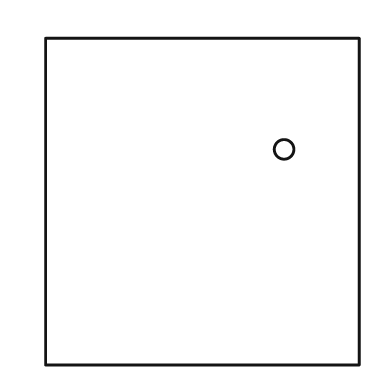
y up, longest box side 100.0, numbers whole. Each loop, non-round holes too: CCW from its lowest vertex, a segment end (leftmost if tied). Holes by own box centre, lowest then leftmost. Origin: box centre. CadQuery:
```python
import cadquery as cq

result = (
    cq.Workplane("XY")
    .moveTo(-48.0, -50.0)
    .lineTo(48.0, -50.0)
    .lineTo(48.0, 50.0)
    .lineTo(-48.0, 50.0)
    .close()
    .moveTo(25.0, 16.0)
    .circle(3.0)
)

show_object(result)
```